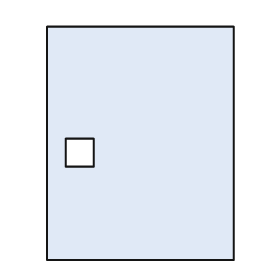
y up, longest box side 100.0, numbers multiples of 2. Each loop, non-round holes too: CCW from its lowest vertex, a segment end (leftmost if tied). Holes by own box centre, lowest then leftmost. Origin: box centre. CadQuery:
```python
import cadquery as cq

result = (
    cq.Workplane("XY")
    .moveTo(-40.0, -50.0)
    .lineTo(40.0, -50.0)
    .lineTo(40.0, 50.0)
    .lineTo(-40.0, 50.0)
    .close()
    .moveTo(-32.0, -10.0)
    .lineTo(-20.0, -10.0)
    .lineTo(-20.0, 2.0)
    .lineTo(-32.0, 2.0)
    .close()
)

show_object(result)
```